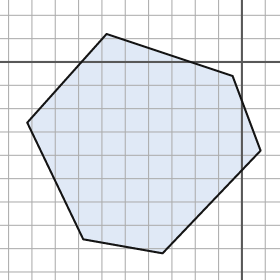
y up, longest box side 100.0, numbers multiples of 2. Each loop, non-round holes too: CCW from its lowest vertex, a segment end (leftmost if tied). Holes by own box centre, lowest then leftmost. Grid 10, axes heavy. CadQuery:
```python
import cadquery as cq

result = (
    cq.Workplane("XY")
    .moveTo(-34.0, -82.0)
    .lineTo(8.0, -38.0)
    .lineTo(-4.0, -6.0)
    .lineTo(-58.0, 12.0)
    .lineTo(-92.0, -26.0)
    .lineTo(-68.0, -76.0)
    .close()
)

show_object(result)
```